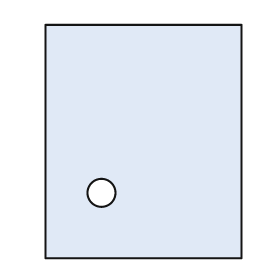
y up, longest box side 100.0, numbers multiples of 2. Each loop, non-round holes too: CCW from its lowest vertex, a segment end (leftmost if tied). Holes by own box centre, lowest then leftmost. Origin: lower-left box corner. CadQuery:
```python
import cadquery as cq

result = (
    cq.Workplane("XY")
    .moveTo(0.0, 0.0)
    .lineTo(84.0, 0.0)
    .lineTo(84.0, 100.0)
    .lineTo(0.0, 100.0)
    .close()
    .moveTo(24.0, 28.0)
    .circle(6.0)
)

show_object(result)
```